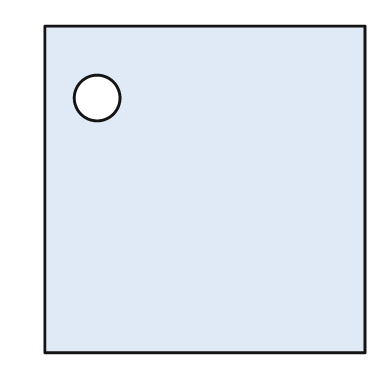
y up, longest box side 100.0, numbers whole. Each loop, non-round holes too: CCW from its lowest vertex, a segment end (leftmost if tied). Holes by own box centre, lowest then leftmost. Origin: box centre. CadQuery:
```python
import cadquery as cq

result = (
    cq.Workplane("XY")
    .moveTo(-49.0, -50.0)
    .lineTo(49.0, -50.0)
    .lineTo(49.0, 50.0)
    .lineTo(-49.0, 50.0)
    .close()
    .moveTo(-33.0, 28.0)
    .circle(7.0)
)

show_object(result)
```